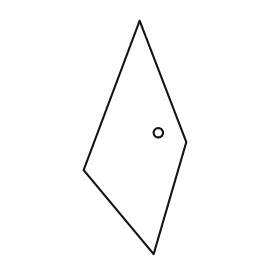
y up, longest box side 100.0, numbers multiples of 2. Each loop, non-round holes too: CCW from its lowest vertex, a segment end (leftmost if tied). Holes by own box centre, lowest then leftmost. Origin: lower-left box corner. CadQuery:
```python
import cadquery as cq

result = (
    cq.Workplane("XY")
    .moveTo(30.0, 0.0)
    .lineTo(44.0, 48.0)
    .lineTo(24.0, 100.0)
    .lineTo(0.0, 36.0)
    .close()
    .moveTo(32.0, 52.0)
    .circle(2.0)
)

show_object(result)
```